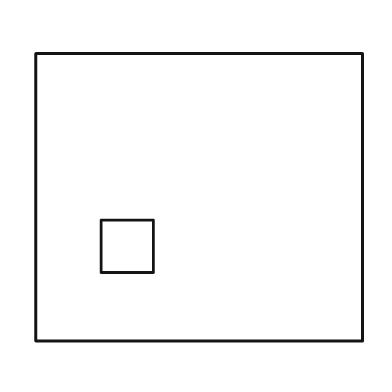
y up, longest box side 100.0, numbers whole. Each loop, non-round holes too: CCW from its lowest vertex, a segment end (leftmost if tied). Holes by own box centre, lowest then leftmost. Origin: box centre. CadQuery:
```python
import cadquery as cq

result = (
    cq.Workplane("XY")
    .moveTo(-50.0, -44.0)
    .lineTo(50.0, -44.0)
    .lineTo(50.0, 44.0)
    .lineTo(-50.0, 44.0)
    .close()
    .moveTo(-30.0, -23.0)
    .lineTo(-14.0, -23.0)
    .lineTo(-14.0, -7.0)
    .lineTo(-30.0, -7.0)
    .close()
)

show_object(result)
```